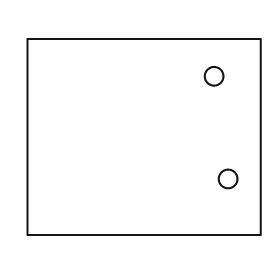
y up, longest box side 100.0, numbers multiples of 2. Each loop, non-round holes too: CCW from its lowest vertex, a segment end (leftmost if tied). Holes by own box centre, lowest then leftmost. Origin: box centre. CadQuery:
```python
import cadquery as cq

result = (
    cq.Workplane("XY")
    .moveTo(-50.0, -42.0)
    .lineTo(50.0, -42.0)
    .lineTo(50.0, 42.0)
    .lineTo(-50.0, 42.0)
    .close()
    .moveTo(36.0, -18.0)
    .circle(4.0)
    .moveTo(30.0, 26.0)
    .circle(4.0)
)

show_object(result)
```